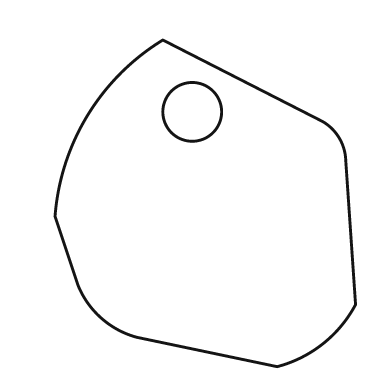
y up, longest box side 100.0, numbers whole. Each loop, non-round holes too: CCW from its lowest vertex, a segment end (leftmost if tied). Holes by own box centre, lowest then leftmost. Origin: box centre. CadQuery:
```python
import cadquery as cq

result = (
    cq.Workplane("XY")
    .moveTo(22.0, -50.0)
    .threePointArc((36.0, -43.0), (46.0, -31.0))
    .lineTo(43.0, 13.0)
    .threePointArc((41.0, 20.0), (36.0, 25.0))
    .lineTo(-13.0, 50.0)
    .threePointArc((-36.0, 27.0), (-46.0, -4.0))
    .lineTo(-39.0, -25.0)
    .threePointArc((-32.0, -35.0), (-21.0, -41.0))
    .close()
    .moveTo(-4.0, 28.0)
    .circle(9.0)
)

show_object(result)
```